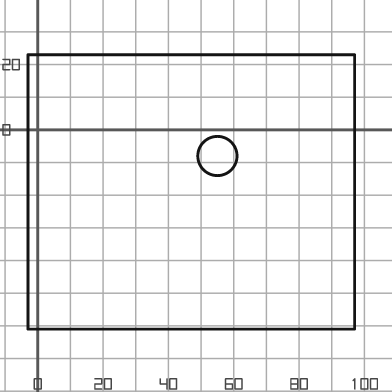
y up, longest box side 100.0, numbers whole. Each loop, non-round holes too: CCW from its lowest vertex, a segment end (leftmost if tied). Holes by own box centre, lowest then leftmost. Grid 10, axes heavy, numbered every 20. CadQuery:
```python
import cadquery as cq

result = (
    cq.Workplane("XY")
    .moveTo(-3.0, -61.0)
    .lineTo(97.0, -61.0)
    .lineTo(97.0, 23.0)
    .lineTo(-3.0, 23.0)
    .close()
    .moveTo(55.0, -8.0)
    .circle(6.0)
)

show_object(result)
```